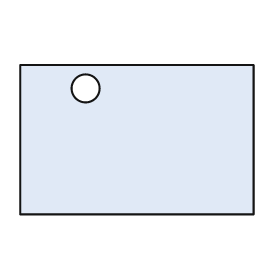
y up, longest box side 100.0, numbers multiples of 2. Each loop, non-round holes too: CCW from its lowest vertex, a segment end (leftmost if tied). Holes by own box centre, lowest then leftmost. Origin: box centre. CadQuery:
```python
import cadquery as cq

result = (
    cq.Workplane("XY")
    .moveTo(-50.0, -32.0)
    .lineTo(50.0, -32.0)
    .lineTo(50.0, 32.0)
    .lineTo(-50.0, 32.0)
    .close()
    .moveTo(-22.0, 22.0)
    .circle(6.0)
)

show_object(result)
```